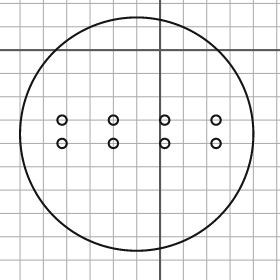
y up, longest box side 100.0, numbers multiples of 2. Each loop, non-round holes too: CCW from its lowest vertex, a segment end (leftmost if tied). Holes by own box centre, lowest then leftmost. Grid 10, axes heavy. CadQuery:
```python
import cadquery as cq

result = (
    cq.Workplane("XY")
    .moveTo(-10.0, -36.0)
    .circle(50.0)
    .moveTo(-42.0, -40.0)
    .circle(2.0)
    .moveTo(-20.0, -40.0)
    .circle(2.0)
    .moveTo(2.0, -40.0)
    .circle(2.0)
    .moveTo(24.0, -40.0)
    .circle(2.0)
    .moveTo(-42.0, -30.0)
    .circle(2.0)
    .moveTo(-20.0, -30.0)
    .circle(2.0)
    .moveTo(2.0, -30.0)
    .circle(2.0)
    .moveTo(24.0, -30.0)
    .circle(2.0)
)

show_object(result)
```